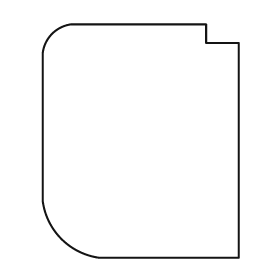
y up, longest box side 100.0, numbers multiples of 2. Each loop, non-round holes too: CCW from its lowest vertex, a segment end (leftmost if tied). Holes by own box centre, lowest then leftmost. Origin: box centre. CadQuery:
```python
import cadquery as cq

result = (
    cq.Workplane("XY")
    .moveTo(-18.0, -50.0)
    .lineTo(42.0, -50.0)
    .lineTo(42.0, 42.0)
    .lineTo(28.0, 42.0)
    .lineTo(28.0, 50.0)
    .lineTo(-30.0, 50.0)
    .threePointArc((-38.0, 46.0), (-42.0, 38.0))
    .lineTo(-42.0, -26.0)
    .threePointArc((-34.0, -42.0), (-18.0, -50.0))
    .close()
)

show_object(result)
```